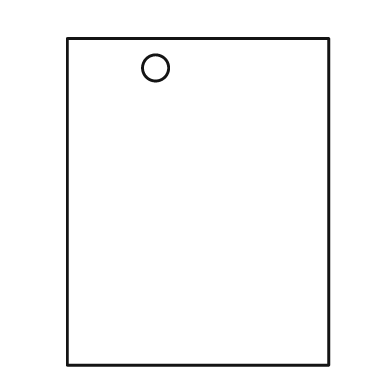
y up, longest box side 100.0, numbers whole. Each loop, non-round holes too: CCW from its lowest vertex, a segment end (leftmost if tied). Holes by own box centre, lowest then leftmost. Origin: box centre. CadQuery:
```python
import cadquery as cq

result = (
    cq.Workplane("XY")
    .moveTo(-40.0, -50.0)
    .lineTo(40.0, -50.0)
    .lineTo(40.0, 50.0)
    .lineTo(-40.0, 50.0)
    .close()
    .moveTo(-13.0, 41.0)
    .circle(4.0)
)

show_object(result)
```